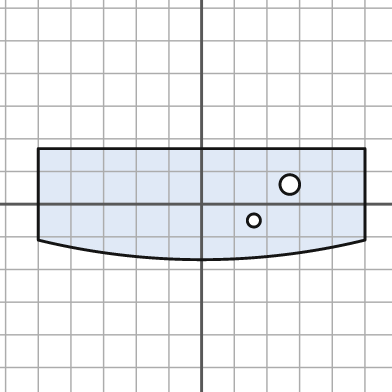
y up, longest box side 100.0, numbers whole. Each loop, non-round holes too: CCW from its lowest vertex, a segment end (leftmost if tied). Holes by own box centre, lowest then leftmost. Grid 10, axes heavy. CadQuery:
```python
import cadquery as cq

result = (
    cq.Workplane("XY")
    .moveTo(-50.0, -11.0)
    .threePointArc((0.0, -17.0), (50.0, -11.0))
    .lineTo(50.0, 17.0)
    .lineTo(-50.0, 17.0)
    .close()
    .moveTo(16.0, -5.0)
    .circle(2.0)
    .moveTo(27.0, 6.0)
    .circle(3.0)
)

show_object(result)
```